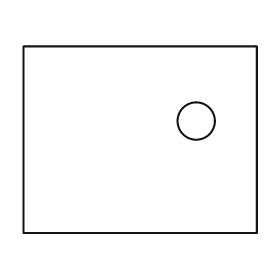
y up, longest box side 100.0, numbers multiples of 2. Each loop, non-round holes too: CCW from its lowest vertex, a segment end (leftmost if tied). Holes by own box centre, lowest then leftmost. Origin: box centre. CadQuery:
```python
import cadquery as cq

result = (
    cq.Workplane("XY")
    .moveTo(-50.0, -40.0)
    .lineTo(50.0, -40.0)
    .lineTo(50.0, 40.0)
    .lineTo(-50.0, 40.0)
    .close()
    .moveTo(24.0, 8.0)
    .circle(8.0)
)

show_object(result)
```